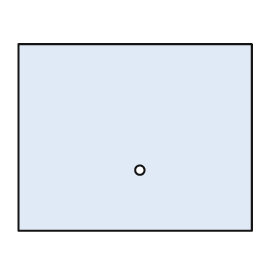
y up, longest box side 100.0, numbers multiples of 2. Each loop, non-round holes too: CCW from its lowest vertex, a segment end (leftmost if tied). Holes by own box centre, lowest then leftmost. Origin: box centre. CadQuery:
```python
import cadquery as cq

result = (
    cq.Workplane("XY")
    .moveTo(-50.0, -40.0)
    .lineTo(50.0, -40.0)
    .lineTo(50.0, 40.0)
    .lineTo(-50.0, 40.0)
    .close()
    .moveTo(2.0, -14.0)
    .circle(2.0)
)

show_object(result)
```